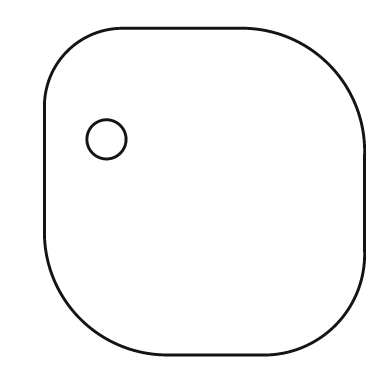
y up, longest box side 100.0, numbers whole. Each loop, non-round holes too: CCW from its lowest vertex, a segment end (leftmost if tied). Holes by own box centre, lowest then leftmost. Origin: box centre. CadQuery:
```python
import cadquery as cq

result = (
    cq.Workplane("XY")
    .moveTo(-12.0, -50.0)
    .lineTo(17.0, -50.0)
    .threePointArc((40.0, -41.0), (49.0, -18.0))
    .lineTo(49.0, 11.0)
    .threePointArc((38.0, 39.0), (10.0, 50.0))
    .lineTo(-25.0, 50.0)
    .threePointArc((-42.0, 43.0), (-49.0, 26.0))
    .lineTo(-49.0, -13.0)
    .threePointArc((-38.0, -39.0), (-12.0, -50.0))
    .close()
    .moveTo(-30.0, 16.0)
    .circle(6.0)
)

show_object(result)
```